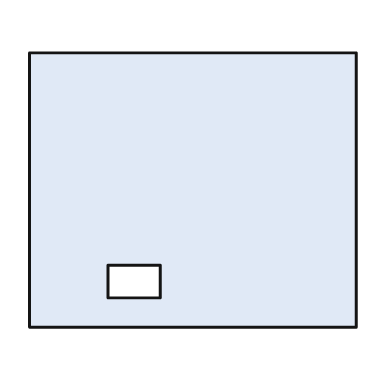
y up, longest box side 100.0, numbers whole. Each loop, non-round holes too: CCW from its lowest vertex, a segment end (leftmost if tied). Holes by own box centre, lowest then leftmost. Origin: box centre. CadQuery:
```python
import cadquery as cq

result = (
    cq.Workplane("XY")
    .moveTo(-50.0, -42.0)
    .lineTo(50.0, -42.0)
    .lineTo(50.0, 42.0)
    .lineTo(-50.0, 42.0)
    .close()
    .moveTo(-26.0, -33.0)
    .lineTo(-10.0, -33.0)
    .lineTo(-10.0, -23.0)
    .lineTo(-26.0, -23.0)
    .close()
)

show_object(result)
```